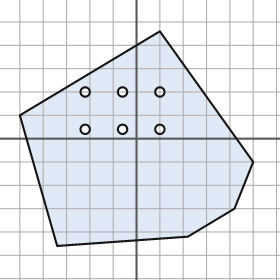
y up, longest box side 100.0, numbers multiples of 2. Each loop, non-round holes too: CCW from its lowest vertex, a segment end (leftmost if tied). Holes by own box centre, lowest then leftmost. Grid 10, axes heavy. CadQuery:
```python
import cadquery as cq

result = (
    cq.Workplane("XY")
    .moveTo(-34.0, -46.0)
    .lineTo(22.0, -42.0)
    .lineTo(42.0, -30.0)
    .lineTo(50.0, -10.0)
    .lineTo(10.0, 46.0)
    .lineTo(-50.0, 10.0)
    .close()
    .moveTo(-22.0, 4.0)
    .circle(2.0)
    .moveTo(-6.0, 4.0)
    .circle(2.0)
    .moveTo(10.0, 4.0)
    .circle(2.0)
    .moveTo(-22.0, 20.0)
    .circle(2.0)
    .moveTo(-6.0, 20.0)
    .circle(2.0)
    .moveTo(10.0, 20.0)
    .circle(2.0)
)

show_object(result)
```